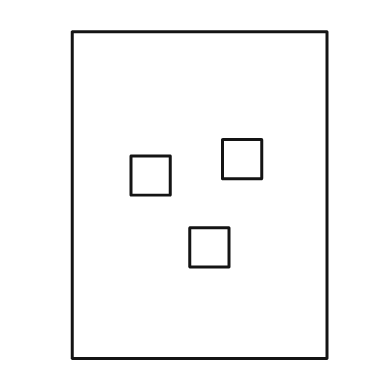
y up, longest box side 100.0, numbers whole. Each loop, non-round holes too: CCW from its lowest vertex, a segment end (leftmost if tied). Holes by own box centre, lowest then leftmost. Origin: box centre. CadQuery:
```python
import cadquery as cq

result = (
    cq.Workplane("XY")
    .moveTo(-39.0, -50.0)
    .lineTo(39.0, -50.0)
    .lineTo(39.0, 50.0)
    .lineTo(-39.0, 50.0)
    .close()
    .moveTo(-3.0, -22.0)
    .lineTo(9.0, -22.0)
    .lineTo(9.0, -10.0)
    .lineTo(-3.0, -10.0)
    .close()
    .moveTo(-21.0, 0.0)
    .lineTo(-9.0, 0.0)
    .lineTo(-9.0, 12.0)
    .lineTo(-21.0, 12.0)
    .close()
    .moveTo(7.0, 5.0)
    .lineTo(19.0, 5.0)
    .lineTo(19.0, 17.0)
    .lineTo(7.0, 17.0)
    .close()
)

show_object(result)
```